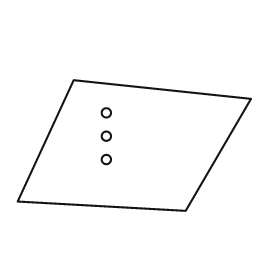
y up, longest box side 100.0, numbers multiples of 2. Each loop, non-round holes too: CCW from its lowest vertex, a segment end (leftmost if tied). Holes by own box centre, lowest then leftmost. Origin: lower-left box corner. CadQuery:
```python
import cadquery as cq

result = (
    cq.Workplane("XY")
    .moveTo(72.0, 0.0)
    .lineTo(100.0, 48.0)
    .lineTo(24.0, 56.0)
    .lineTo(0.0, 4.0)
    .close()
    .moveTo(38.0, 22.0)
    .circle(2.0)
    .moveTo(38.0, 32.0)
    .circle(2.0)
    .moveTo(38.0, 42.0)
    .circle(2.0)
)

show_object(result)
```